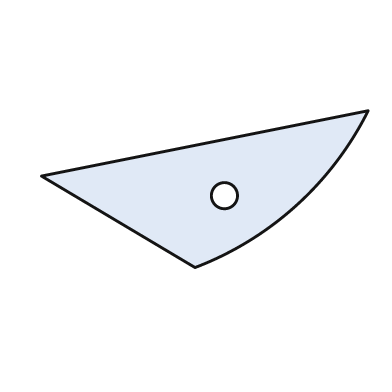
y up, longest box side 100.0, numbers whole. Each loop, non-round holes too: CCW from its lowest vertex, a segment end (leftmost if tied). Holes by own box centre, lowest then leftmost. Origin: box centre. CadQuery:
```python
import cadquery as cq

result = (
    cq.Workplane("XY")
    .moveTo(-3.0, -24.0)
    .threePointArc((28.0, -5.0), (50.0, 24.0))
    .lineTo(-50.0, 4.0)
    .close()
    .moveTo(6.0, -2.0)
    .circle(4.0)
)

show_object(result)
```